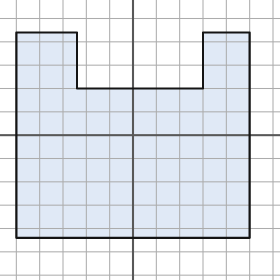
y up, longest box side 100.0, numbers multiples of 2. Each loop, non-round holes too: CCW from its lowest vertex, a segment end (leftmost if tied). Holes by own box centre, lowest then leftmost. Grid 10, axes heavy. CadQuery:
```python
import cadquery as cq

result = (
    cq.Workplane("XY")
    .moveTo(-50.0, -44.0)
    .lineTo(50.0, -44.0)
    .lineTo(50.0, 44.0)
    .lineTo(30.0, 44.0)
    .lineTo(30.0, 20.0)
    .lineTo(-24.0, 20.0)
    .lineTo(-24.0, 44.0)
    .lineTo(-50.0, 44.0)
    .close()
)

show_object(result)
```